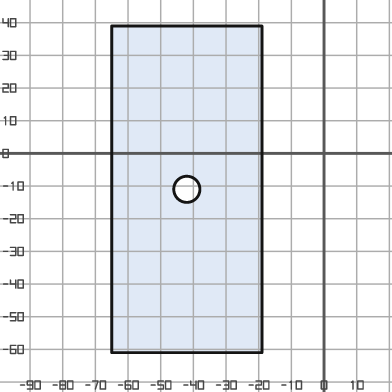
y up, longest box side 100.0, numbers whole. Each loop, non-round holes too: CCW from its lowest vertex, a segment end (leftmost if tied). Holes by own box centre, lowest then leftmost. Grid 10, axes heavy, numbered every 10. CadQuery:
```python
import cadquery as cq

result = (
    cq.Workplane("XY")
    .moveTo(-65.0, -61.0)
    .lineTo(-19.0, -61.0)
    .lineTo(-19.0, 39.0)
    .lineTo(-65.0, 39.0)
    .close()
    .moveTo(-42.0, -11.0)
    .circle(4.0)
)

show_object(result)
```